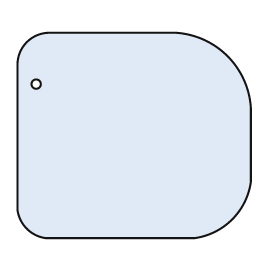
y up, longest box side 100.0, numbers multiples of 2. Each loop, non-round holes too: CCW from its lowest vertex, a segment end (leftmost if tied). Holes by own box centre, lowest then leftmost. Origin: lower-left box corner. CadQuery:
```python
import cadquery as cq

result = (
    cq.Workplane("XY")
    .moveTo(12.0, 0.0)
    .lineTo(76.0, 0.0)
    .threePointArc((92.0, 8.0), (100.0, 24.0))
    .lineTo(100.0, 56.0)
    .threePointArc((90.0, 78.0), (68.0, 88.0))
    .lineTo(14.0, 88.0)
    .threePointArc((4.0, 84.0), (0.0, 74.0))
    .lineTo(0.0, 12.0)
    .threePointArc((4.0, 4.0), (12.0, 0.0))
    .close()
    .moveTo(8.0, 66.0)
    .circle(2.0)
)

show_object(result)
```